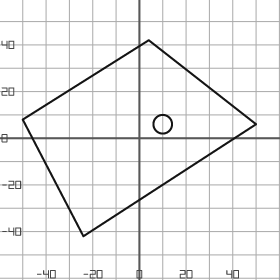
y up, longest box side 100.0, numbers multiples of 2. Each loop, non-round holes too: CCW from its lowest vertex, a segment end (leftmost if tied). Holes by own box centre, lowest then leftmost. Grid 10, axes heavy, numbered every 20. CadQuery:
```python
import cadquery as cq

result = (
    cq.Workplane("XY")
    .moveTo(-24.0, -42.0)
    .lineTo(50.0, 6.0)
    .lineTo(4.0, 42.0)
    .lineTo(-50.0, 8.0)
    .close()
    .moveTo(10.0, 6.0)
    .circle(4.0)
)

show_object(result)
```